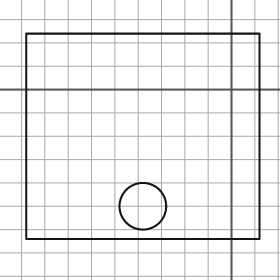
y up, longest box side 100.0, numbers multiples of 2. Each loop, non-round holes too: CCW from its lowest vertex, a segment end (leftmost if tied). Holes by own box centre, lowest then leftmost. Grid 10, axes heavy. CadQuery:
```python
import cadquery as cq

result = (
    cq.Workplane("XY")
    .moveTo(-88.0, -64.0)
    .lineTo(12.0, -64.0)
    .lineTo(12.0, 24.0)
    .lineTo(-88.0, 24.0)
    .close()
    .moveTo(-38.0, -50.0)
    .circle(10.0)
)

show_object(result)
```